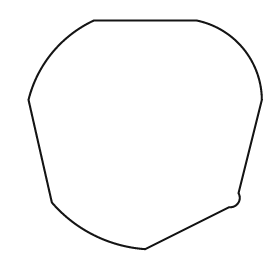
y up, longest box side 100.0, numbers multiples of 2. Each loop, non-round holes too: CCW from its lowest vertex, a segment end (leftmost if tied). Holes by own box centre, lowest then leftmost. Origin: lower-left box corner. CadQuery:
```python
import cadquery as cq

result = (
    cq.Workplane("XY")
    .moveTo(50.0, 0.0)
    .lineTo(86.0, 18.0)
    .threePointArc((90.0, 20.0), (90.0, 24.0))
    .lineTo(100.0, 64.0)
    .threePointArc((92.0, 86.0), (72.0, 98.0))
    .lineTo(28.0, 98.0)
    .threePointArc((10.0, 84.0), (0.0, 64.0))
    .lineTo(10.0, 20.0)
    .threePointArc((28.0, 6.0), (50.0, 0.0))
    .close()
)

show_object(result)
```